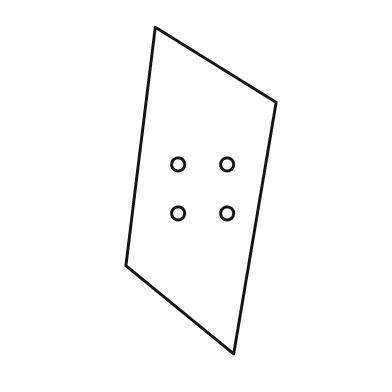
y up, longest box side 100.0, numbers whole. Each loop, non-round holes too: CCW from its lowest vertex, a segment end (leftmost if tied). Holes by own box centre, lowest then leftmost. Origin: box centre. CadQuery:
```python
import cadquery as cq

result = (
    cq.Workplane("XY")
    .moveTo(10.0, -50.0)
    .lineTo(23.0, 27.0)
    .lineTo(-14.0, 50.0)
    .lineTo(-23.0, -23.0)
    .close()
    .moveTo(-7.0, -7.0)
    .circle(2.0)
    .moveTo(8.0, -7.0)
    .circle(2.0)
    .moveTo(-7.0, 8.0)
    .circle(2.0)
    .moveTo(8.0, 8.0)
    .circle(2.0)
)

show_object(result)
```